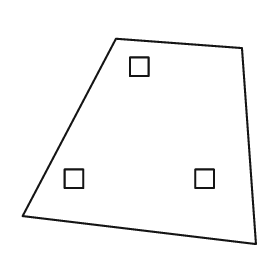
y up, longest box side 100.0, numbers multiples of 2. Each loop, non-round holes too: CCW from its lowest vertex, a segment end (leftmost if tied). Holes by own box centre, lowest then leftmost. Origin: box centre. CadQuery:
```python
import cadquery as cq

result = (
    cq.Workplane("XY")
    .moveTo(50.0, -44.0)
    .lineTo(44.0, 40.0)
    .lineTo(-10.0, 44.0)
    .lineTo(-50.0, -32.0)
    .close()
    .moveTo(-32.0, -20.0)
    .lineTo(-24.0, -20.0)
    .lineTo(-24.0, -12.0)
    .lineTo(-32.0, -12.0)
    .close()
    .moveTo(24.0, -20.0)
    .lineTo(32.0, -20.0)
    .lineTo(32.0, -12.0)
    .lineTo(24.0, -12.0)
    .close()
    .moveTo(-4.0, 28.0)
    .lineTo(4.0, 28.0)
    .lineTo(4.0, 36.0)
    .lineTo(-4.0, 36.0)
    .close()
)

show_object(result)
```